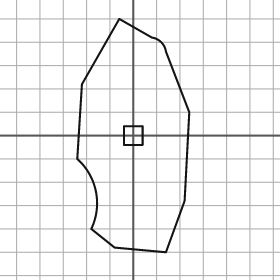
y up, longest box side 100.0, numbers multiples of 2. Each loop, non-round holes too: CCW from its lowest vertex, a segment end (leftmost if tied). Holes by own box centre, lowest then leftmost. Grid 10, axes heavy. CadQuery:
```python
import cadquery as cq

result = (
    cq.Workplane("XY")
    .moveTo(14.0, -50.0)
    .lineTo(22.0, -28.0)
    .lineTo(24.0, 10.0)
    .lineTo(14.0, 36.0)
    .threePointArc((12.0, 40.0), (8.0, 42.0))
    .lineTo(-6.0, 50.0)
    .lineTo(-22.0, 22.0)
    .lineTo(-24.0, -10.0)
    .threePointArc((-16.0, -24.0), (-18.0, -40.0))
    .lineTo(-8.0, -48.0)
    .close()
    .moveTo(-4.0, -4.0)
    .lineTo(4.0, -4.0)
    .lineTo(4.0, 4.0)
    .lineTo(-4.0, 4.0)
    .close()
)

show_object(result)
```